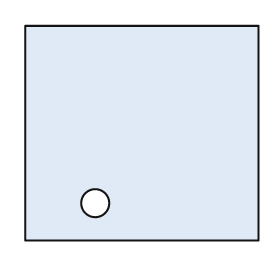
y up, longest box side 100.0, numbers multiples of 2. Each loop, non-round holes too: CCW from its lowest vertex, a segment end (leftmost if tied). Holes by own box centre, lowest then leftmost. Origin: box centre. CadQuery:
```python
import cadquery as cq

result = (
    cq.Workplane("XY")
    .moveTo(-50.0, -46.0)
    .lineTo(50.0, -46.0)
    .lineTo(50.0, 46.0)
    .lineTo(-50.0, 46.0)
    .close()
    .moveTo(-20.0, -30.0)
    .circle(6.0)
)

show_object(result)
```